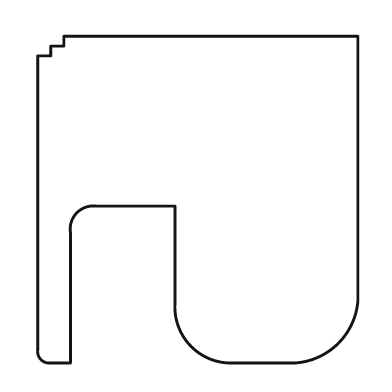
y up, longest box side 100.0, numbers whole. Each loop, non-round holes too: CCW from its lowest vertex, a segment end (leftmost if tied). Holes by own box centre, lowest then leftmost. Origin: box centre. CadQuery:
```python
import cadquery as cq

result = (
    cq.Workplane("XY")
    .moveTo(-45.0, -50.0)
    .lineTo(-39.0, -50.0)
    .lineTo(-39.0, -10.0)
    .threePointArc((-37.0, -4.0), (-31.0, -2.0))
    .lineTo(-7.0, -2.0)
    .lineTo(-7.0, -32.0)
    .threePointArc((-2.0, -45.0), (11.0, -50.0))
    .lineTo(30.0, -50.0)
    .threePointArc((43.0, -44.0), (49.0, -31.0))
    .lineTo(49.0, 50.0)
    .lineTo(-41.0, 50.0)
    .lineTo(-41.0, 47.0)
    .lineTo(-45.0, 47.0)
    .lineTo(-45.0, 44.0)
    .lineTo(-49.0, 44.0)
    .lineTo(-49.0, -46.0)
    .threePointArc((-48.0, -49.0), (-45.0, -50.0))
    .close()
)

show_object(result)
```